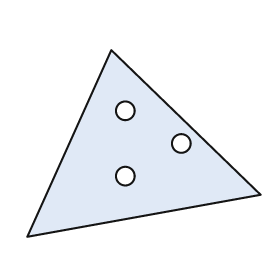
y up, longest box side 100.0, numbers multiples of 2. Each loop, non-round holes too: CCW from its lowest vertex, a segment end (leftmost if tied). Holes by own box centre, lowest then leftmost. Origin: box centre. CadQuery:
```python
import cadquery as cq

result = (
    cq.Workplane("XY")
    .moveTo(-50.0, -40.0)
    .lineTo(50.0, -22.0)
    .lineTo(-14.0, 40.0)
    .close()
    .moveTo(-8.0, -14.0)
    .circle(4.0)
    .moveTo(16.0, 0.0)
    .circle(4.0)
    .moveTo(-8.0, 14.0)
    .circle(4.0)
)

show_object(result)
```